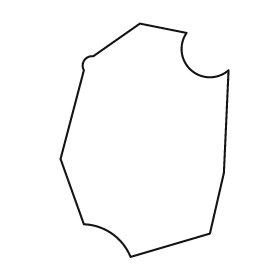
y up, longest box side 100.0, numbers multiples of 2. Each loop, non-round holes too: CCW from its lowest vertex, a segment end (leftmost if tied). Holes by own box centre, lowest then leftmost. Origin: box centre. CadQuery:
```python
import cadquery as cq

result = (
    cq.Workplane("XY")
    .moveTo(-6.0, -50.0)
    .lineTo(28.0, -40.0)
    .lineTo(34.0, -14.0)
    .lineTo(36.0, 30.0)
    .threePointArc((20.0, 30.0), (18.0, 46.0))
    .lineTo(-2.0, 50.0)
    .lineTo(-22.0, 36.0)
    .threePointArc((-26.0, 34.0), (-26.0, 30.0))
    .lineTo(-36.0, -8.0)
    .lineTo(-26.0, -36.0)
    .threePointArc((-14.0, -40.0), (-6.0, -50.0))
    .close()
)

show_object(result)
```